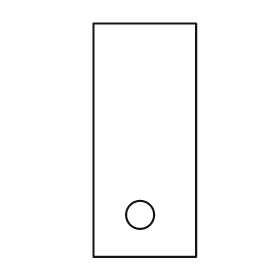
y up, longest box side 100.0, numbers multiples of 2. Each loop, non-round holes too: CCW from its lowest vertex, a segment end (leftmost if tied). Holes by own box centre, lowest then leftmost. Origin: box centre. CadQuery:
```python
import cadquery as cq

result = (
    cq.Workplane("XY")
    .moveTo(-22.0, -50.0)
    .lineTo(22.0, -50.0)
    .lineTo(22.0, 50.0)
    .lineTo(-22.0, 50.0)
    .close()
    .moveTo(-2.0, -32.0)
    .circle(6.0)
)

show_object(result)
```